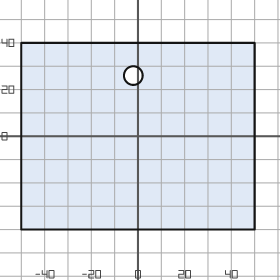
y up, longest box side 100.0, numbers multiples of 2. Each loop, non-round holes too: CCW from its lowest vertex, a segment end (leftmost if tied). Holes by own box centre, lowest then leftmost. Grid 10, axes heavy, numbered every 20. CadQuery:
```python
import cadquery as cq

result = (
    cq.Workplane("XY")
    .moveTo(-50.0, -40.0)
    .lineTo(50.0, -40.0)
    .lineTo(50.0, 40.0)
    .lineTo(-50.0, 40.0)
    .close()
    .moveTo(-2.0, 26.0)
    .circle(4.0)
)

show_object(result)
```